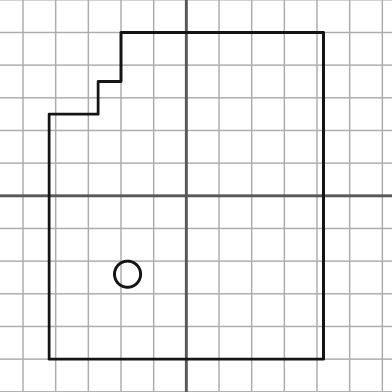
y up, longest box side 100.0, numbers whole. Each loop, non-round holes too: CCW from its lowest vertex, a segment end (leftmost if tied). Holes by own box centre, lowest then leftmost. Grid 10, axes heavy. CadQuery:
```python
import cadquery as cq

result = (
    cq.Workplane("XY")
    .moveTo(-42.0, -50.0)
    .lineTo(42.0, -50.0)
    .lineTo(42.0, 50.0)
    .lineTo(-20.0, 50.0)
    .lineTo(-20.0, 35.0)
    .lineTo(-27.0, 35.0)
    .lineTo(-27.0, 25.0)
    .lineTo(-42.0, 25.0)
    .close()
    .moveTo(-18.0, -24.0)
    .circle(4.0)
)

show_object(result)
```